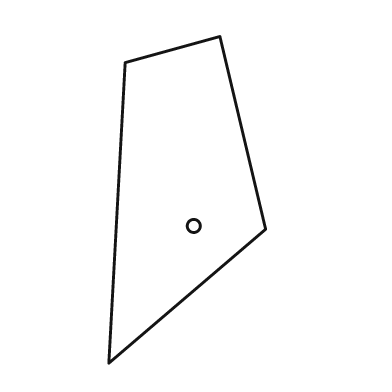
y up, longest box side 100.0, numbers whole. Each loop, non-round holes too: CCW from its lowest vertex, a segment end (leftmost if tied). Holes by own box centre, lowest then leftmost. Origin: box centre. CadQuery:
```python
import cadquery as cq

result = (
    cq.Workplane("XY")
    .moveTo(-24.0, -50.0)
    .lineTo(24.0, -9.0)
    .lineTo(10.0, 50.0)
    .lineTo(-19.0, 42.0)
    .close()
    .moveTo(2.0, -8.0)
    .circle(2.0)
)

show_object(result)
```